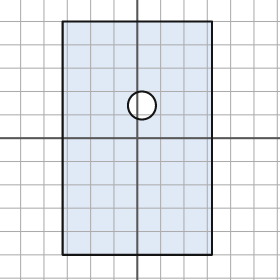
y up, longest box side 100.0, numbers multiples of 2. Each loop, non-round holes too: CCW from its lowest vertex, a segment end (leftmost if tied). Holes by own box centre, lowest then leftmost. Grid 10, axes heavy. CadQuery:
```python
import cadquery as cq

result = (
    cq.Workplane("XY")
    .moveTo(-32.0, -50.0)
    .lineTo(32.0, -50.0)
    .lineTo(32.0, 50.0)
    .lineTo(-32.0, 50.0)
    .close()
    .moveTo(2.0, 14.0)
    .circle(6.0)
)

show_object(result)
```